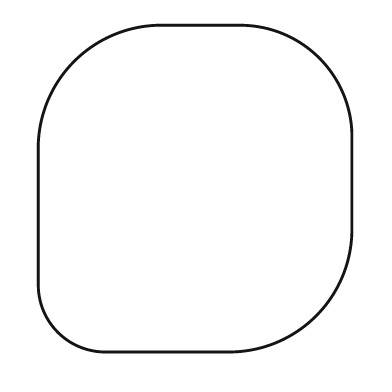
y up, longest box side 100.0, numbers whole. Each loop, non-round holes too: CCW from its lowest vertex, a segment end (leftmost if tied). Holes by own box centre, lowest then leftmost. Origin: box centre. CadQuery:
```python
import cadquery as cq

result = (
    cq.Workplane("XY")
    .moveTo(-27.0, -50.0)
    .lineTo(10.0, -50.0)
    .threePointArc((37.0, -39.0), (48.0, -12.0))
    .lineTo(48.0, 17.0)
    .threePointArc((38.0, 40.0), (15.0, 50.0))
    .lineTo(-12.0, 50.0)
    .threePointArc((-37.0, 39.0), (-48.0, 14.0))
    .lineTo(-48.0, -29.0)
    .threePointArc((-42.0, -44.0), (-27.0, -50.0))
    .close()
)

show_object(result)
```